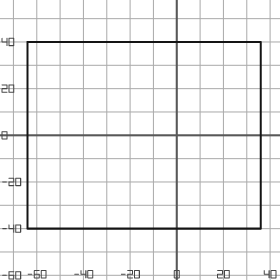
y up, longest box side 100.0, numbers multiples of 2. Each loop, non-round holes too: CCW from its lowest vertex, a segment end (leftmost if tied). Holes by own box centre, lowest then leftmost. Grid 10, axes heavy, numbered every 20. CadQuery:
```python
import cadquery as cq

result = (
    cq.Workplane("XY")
    .moveTo(-64.0, -40.0)
    .lineTo(36.0, -40.0)
    .lineTo(36.0, 40.0)
    .lineTo(-64.0, 40.0)
    .close()
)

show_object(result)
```